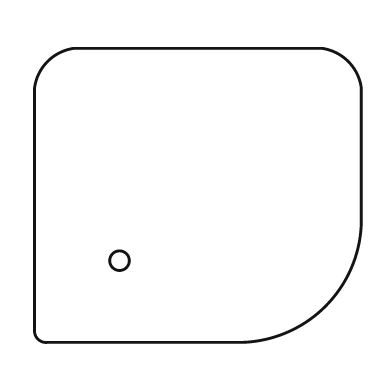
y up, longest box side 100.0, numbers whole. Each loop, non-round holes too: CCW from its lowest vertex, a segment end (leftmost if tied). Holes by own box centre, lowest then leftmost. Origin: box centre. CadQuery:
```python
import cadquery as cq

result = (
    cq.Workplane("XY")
    .moveTo(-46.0, -45.0)
    .lineTo(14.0, -45.0)
    .threePointArc((39.0, -34.0), (50.0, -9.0))
    .lineTo(50.0, 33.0)
    .threePointArc((46.0, 41.0), (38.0, 45.0))
    .lineTo(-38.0, 45.0)
    .threePointArc((-46.0, 41.0), (-50.0, 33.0))
    .lineTo(-50.0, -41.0)
    .threePointArc((-49.0, -44.0), (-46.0, -45.0))
    .close()
    .moveTo(-24.0, -20.0)
    .circle(3.0)
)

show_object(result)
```